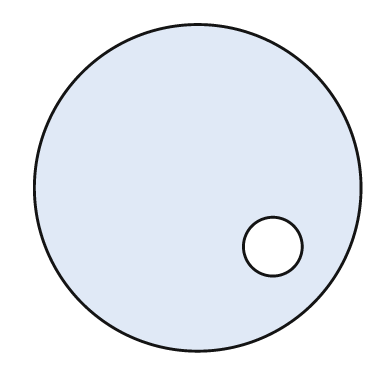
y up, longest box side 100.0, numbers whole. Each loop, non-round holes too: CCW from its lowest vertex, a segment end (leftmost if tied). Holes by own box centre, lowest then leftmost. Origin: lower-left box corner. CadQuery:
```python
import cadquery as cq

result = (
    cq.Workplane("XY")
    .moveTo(50.0, 50.0)
    .circle(50.0)
    .moveTo(73.0, 32.0)
    .circle(9.0)
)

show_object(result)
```